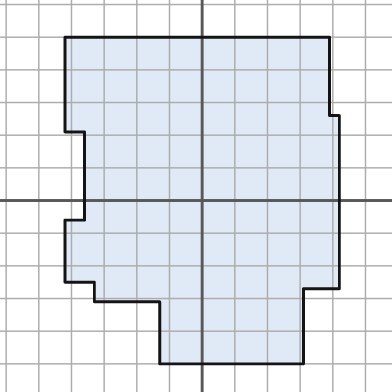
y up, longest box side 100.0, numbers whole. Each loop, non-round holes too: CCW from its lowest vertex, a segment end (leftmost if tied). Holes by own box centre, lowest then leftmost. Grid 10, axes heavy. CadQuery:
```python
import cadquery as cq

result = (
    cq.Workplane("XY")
    .moveTo(-13.0, -50.0)
    .lineTo(31.0, -50.0)
    .lineTo(31.0, -27.0)
    .lineTo(42.0, -27.0)
    .lineTo(42.0, 26.0)
    .lineTo(39.0, 26.0)
    .lineTo(39.0, 50.0)
    .lineTo(-42.0, 50.0)
    .lineTo(-42.0, 21.0)
    .lineTo(-36.0, 21.0)
    .lineTo(-36.0, -6.0)
    .lineTo(-42.0, -6.0)
    .lineTo(-42.0, -25.0)
    .lineTo(-33.0, -25.0)
    .lineTo(-33.0, -31.0)
    .lineTo(-13.0, -31.0)
    .close()
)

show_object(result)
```